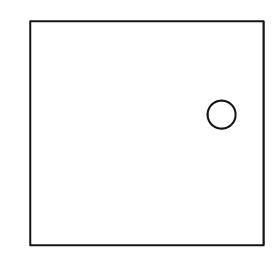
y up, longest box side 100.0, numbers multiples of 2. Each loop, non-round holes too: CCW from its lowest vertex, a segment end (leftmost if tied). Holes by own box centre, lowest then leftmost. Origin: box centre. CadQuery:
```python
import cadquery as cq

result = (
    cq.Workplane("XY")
    .moveTo(-50.0, -48.0)
    .lineTo(50.0, -48.0)
    .lineTo(50.0, 48.0)
    .lineTo(-50.0, 48.0)
    .close()
    .moveTo(32.0, 8.0)
    .circle(6.0)
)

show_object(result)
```